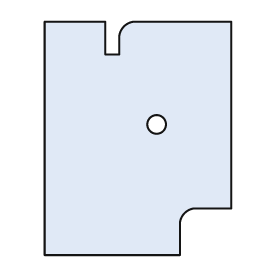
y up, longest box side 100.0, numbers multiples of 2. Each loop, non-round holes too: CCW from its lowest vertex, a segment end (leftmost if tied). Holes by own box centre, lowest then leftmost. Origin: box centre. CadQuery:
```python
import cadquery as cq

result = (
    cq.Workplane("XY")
    .moveTo(-40.0, -50.0)
    .lineTo(18.0, -50.0)
    .lineTo(18.0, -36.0)
    .threePointArc((20.0, -32.0), (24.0, -30.0))
    .lineTo(40.0, -30.0)
    .lineTo(40.0, 50.0)
    .lineTo(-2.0, 50.0)
    .threePointArc((-6.0, 48.0), (-8.0, 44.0))
    .lineTo(-8.0, 36.0)
    .lineTo(-14.0, 36.0)
    .lineTo(-14.0, 50.0)
    .lineTo(-40.0, 50.0)
    .close()
    .moveTo(8.0, 6.0)
    .circle(4.0)
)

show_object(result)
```